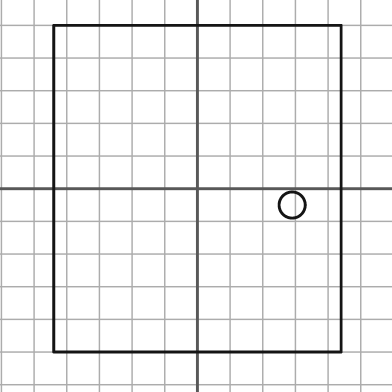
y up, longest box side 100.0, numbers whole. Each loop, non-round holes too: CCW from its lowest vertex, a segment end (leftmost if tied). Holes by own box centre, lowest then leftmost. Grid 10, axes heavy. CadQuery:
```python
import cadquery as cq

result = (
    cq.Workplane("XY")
    .moveTo(-44.0, -50.0)
    .lineTo(44.0, -50.0)
    .lineTo(44.0, 50.0)
    .lineTo(-44.0, 50.0)
    .close()
    .moveTo(29.0, -5.0)
    .circle(4.0)
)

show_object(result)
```